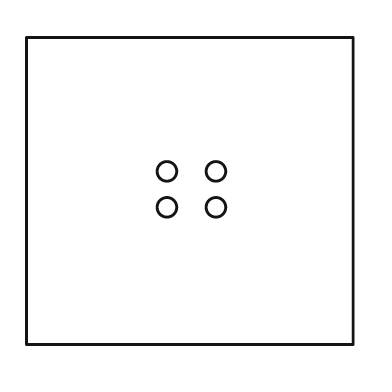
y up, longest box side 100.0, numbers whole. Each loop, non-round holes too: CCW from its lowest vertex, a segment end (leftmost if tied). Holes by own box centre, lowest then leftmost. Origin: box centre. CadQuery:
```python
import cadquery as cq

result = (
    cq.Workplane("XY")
    .moveTo(-50.0, -47.0)
    .lineTo(50.0, -47.0)
    .lineTo(50.0, 47.0)
    .lineTo(-50.0, 47.0)
    .close()
    .moveTo(-7.0, -5.0)
    .circle(3.0)
    .moveTo(8.0, -5.0)
    .circle(3.0)
    .moveTo(-7.0, 6.0)
    .circle(3.0)
    .moveTo(8.0, 6.0)
    .circle(3.0)
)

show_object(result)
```